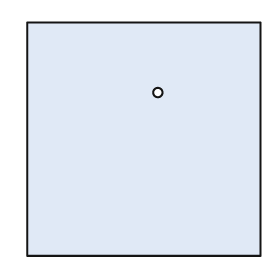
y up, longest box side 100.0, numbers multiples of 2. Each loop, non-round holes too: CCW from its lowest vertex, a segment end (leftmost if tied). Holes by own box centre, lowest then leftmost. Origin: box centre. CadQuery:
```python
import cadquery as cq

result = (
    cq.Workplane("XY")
    .moveTo(-50.0, -50.0)
    .lineTo(50.0, -50.0)
    .lineTo(50.0, 50.0)
    .lineTo(-50.0, 50.0)
    .close()
    .moveTo(6.0, 20.0)
    .circle(2.0)
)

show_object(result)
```